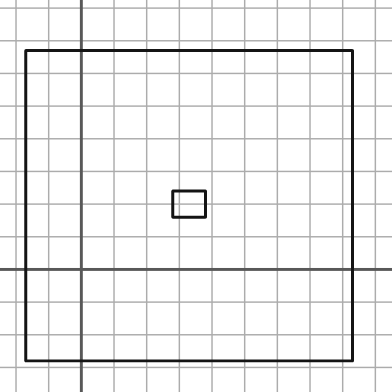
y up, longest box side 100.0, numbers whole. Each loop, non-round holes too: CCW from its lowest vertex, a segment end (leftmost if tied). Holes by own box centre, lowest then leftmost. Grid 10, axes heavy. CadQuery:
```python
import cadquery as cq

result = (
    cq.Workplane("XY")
    .moveTo(-17.0, -28.0)
    .lineTo(83.0, -28.0)
    .lineTo(83.0, 67.0)
    .lineTo(-17.0, 67.0)
    .close()
    .moveTo(28.0, 16.0)
    .lineTo(38.0, 16.0)
    .lineTo(38.0, 24.0)
    .lineTo(28.0, 24.0)
    .close()
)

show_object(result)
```